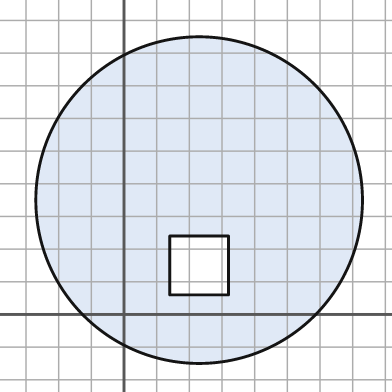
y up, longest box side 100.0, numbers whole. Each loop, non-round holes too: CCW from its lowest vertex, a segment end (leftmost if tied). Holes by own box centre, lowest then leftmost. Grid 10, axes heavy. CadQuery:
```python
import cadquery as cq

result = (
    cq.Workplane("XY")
    .moveTo(23.0, 35.0)
    .circle(50.0)
    .moveTo(14.0, 6.0)
    .lineTo(32.0, 6.0)
    .lineTo(32.0, 24.0)
    .lineTo(14.0, 24.0)
    .close()
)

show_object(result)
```